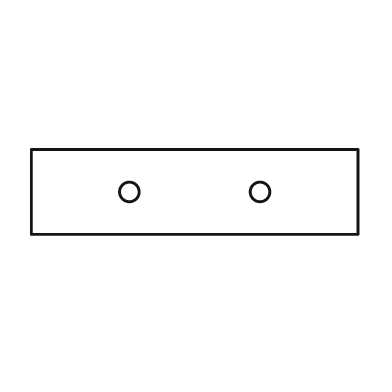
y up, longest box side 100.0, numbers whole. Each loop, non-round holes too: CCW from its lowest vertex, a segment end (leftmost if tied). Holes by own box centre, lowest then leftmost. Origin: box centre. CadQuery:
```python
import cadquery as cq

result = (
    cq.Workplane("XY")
    .moveTo(-50.0, -13.0)
    .lineTo(50.0, -13.0)
    .lineTo(50.0, 13.0)
    .lineTo(-50.0, 13.0)
    .close()
    .moveTo(-20.0, 0.0)
    .circle(3.0)
    .moveTo(20.0, 0.0)
    .circle(3.0)
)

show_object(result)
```